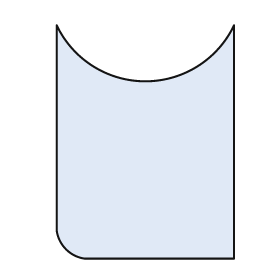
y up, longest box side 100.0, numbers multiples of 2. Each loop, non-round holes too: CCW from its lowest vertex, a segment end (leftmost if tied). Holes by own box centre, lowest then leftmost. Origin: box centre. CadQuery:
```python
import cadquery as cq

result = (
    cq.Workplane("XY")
    .moveTo(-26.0, -50.0)
    .lineTo(38.0, -50.0)
    .lineTo(38.0, 50.0)
    .threePointArc((0.0, 26.0), (-38.0, 50.0))
    .lineTo(-38.0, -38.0)
    .threePointArc((-34.0, -46.0), (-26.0, -50.0))
    .close()
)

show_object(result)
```